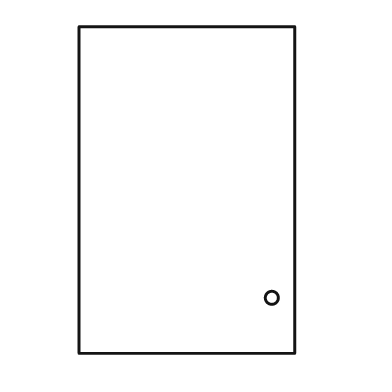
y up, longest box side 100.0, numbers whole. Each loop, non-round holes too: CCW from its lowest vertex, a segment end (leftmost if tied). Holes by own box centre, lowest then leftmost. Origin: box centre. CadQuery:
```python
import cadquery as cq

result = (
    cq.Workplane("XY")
    .moveTo(-33.0, -50.0)
    .lineTo(33.0, -50.0)
    .lineTo(33.0, 50.0)
    .lineTo(-33.0, 50.0)
    .close()
    .moveTo(26.0, -33.0)
    .circle(2.0)
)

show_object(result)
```